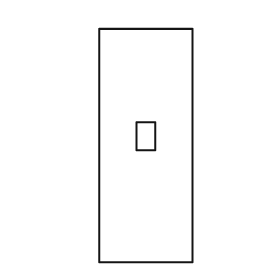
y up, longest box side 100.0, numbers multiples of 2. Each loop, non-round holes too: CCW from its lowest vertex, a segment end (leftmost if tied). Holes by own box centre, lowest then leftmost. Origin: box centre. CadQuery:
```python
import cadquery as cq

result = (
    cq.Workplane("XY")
    .moveTo(-20.0, -50.0)
    .lineTo(20.0, -50.0)
    .lineTo(20.0, 50.0)
    .lineTo(-20.0, 50.0)
    .close()
    .moveTo(-4.0, -2.0)
    .lineTo(4.0, -2.0)
    .lineTo(4.0, 10.0)
    .lineTo(-4.0, 10.0)
    .close()
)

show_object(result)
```